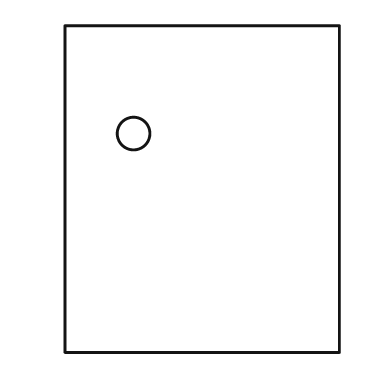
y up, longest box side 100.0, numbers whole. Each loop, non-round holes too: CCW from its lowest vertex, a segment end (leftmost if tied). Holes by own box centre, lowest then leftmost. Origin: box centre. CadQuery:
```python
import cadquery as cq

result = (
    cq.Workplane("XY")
    .moveTo(-42.0, -50.0)
    .lineTo(42.0, -50.0)
    .lineTo(42.0, 50.0)
    .lineTo(-42.0, 50.0)
    .close()
    .moveTo(-21.0, 17.0)
    .circle(5.0)
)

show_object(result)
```